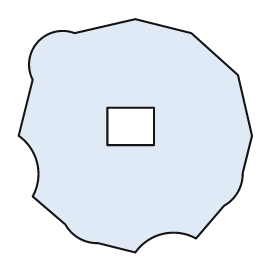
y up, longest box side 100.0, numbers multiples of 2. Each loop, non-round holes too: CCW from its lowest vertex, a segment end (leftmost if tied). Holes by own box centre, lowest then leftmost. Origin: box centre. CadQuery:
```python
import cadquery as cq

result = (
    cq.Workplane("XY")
    .moveTo(0.0, -50.0)
    .threePointArc((12.0, -42.0), (26.0, -44.0))
    .lineTo(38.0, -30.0)
    .threePointArc((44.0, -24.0), (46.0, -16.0))
    .lineTo(50.0, 0.0)
    .lineTo(44.0, 26.0)
    .lineTo(24.0, 44.0)
    .lineTo(0.0, 50.0)
    .lineTo(-26.0, 44.0)
    .threePointArc((-42.0, 40.0), (-44.0, 24.0))
    .lineTo(-50.0, 0.0)
    .threePointArc((-42.0, -12.0), (-44.0, -26.0))
    .lineTo(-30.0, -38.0)
    .threePointArc((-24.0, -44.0), (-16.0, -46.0))
    .close()
    .moveTo(-12.0, -4.0)
    .lineTo(8.0, -4.0)
    .lineTo(8.0, 12.0)
    .lineTo(-12.0, 12.0)
    .close()
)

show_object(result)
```